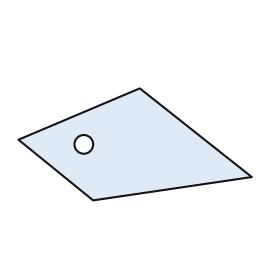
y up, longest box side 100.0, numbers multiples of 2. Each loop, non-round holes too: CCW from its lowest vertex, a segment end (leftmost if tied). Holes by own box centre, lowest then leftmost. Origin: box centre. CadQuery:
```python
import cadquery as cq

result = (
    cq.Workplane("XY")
    .moveTo(-18.0, -24.0)
    .lineTo(50.0, -14.0)
    .lineTo(2.0, 24.0)
    .lineTo(-50.0, 2.0)
    .close()
    .moveTo(-22.0, 0.0)
    .circle(4.0)
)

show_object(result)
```